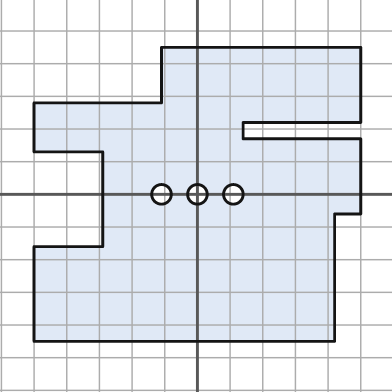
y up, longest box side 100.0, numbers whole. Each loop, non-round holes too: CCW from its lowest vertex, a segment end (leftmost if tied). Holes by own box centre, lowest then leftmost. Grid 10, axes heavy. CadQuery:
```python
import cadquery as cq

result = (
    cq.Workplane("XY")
    .moveTo(-50.0, -45.0)
    .lineTo(42.0, -45.0)
    .lineTo(42.0, -6.0)
    .lineTo(50.0, -6.0)
    .lineTo(50.0, 17.0)
    .lineTo(14.0, 17.0)
    .lineTo(14.0, 22.0)
    .lineTo(50.0, 22.0)
    .lineTo(50.0, 45.0)
    .lineTo(-11.0, 45.0)
    .lineTo(-11.0, 28.0)
    .lineTo(-50.0, 28.0)
    .lineTo(-50.0, 13.0)
    .lineTo(-29.0, 13.0)
    .lineTo(-29.0, -16.0)
    .lineTo(-50.0, -16.0)
    .close()
    .moveTo(-11.0, 0.0)
    .circle(3.0)
    .moveTo(0.0, 0.0)
    .circle(3.0)
    .moveTo(11.0, 0.0)
    .circle(3.0)
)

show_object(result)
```